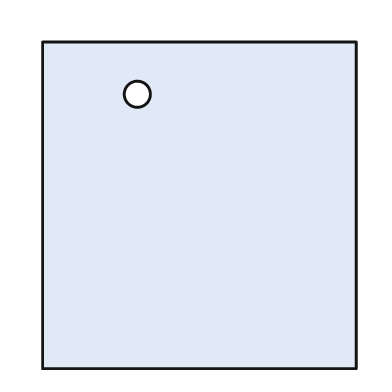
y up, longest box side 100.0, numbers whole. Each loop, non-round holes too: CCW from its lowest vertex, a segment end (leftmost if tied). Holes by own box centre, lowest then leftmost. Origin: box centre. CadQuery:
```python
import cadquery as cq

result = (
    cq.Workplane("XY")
    .moveTo(-48.0, -50.0)
    .lineTo(48.0, -50.0)
    .lineTo(48.0, 50.0)
    .lineTo(-48.0, 50.0)
    .close()
    .moveTo(-19.0, 34.0)
    .circle(4.0)
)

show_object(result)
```